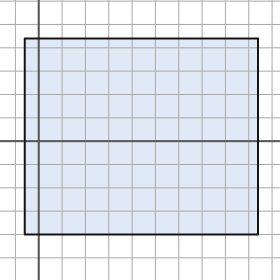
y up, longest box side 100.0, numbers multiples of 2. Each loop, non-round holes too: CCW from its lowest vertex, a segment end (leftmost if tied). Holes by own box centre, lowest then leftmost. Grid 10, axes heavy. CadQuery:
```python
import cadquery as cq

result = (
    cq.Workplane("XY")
    .moveTo(-6.0, -40.0)
    .lineTo(94.0, -40.0)
    .lineTo(94.0, 44.0)
    .lineTo(-6.0, 44.0)
    .close()
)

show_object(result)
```